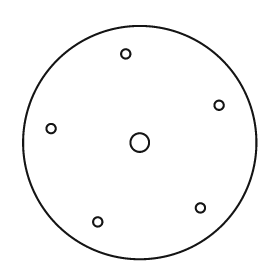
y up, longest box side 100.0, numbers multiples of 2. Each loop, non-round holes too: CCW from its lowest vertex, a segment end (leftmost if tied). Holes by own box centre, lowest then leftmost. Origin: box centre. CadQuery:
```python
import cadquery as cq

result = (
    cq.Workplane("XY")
    .moveTo(0.0, 0.0)
    .circle(50.0)
    .moveTo(-18.0, -34.0)
    .circle(2.0)
    .moveTo(26.0, -28.0)
    .circle(2.0)
    .moveTo(0.0, 0.0)
    .circle(4.0)
    .moveTo(-38.0, 6.0)
    .circle(2.0)
    .moveTo(34.0, 16.0)
    .circle(2.0)
    .moveTo(-6.0, 38.0)
    .circle(2.0)
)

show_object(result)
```